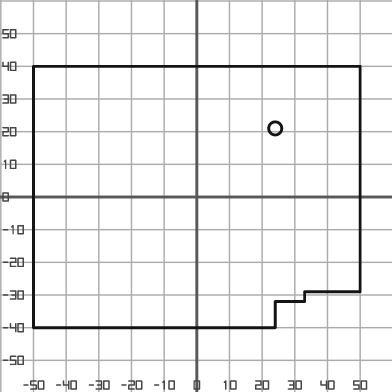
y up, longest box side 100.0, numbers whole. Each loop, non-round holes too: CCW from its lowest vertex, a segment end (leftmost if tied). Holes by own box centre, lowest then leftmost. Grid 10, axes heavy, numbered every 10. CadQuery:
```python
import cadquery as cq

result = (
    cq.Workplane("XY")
    .moveTo(-50.0, -40.0)
    .lineTo(24.0, -40.0)
    .lineTo(24.0, -32.0)
    .lineTo(33.0, -32.0)
    .lineTo(33.0, -29.0)
    .lineTo(50.0, -29.0)
    .lineTo(50.0, 40.0)
    .lineTo(-50.0, 40.0)
    .close()
    .moveTo(24.0, 21.0)
    .circle(2.0)
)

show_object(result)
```